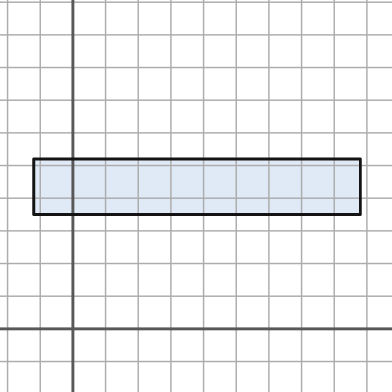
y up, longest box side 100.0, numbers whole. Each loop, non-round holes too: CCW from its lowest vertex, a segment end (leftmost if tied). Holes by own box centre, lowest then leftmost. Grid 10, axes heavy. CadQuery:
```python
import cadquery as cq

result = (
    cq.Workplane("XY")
    .moveTo(-12.0, 35.0)
    .lineTo(88.0, 35.0)
    .lineTo(88.0, 52.0)
    .lineTo(-12.0, 52.0)
    .close()
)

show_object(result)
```